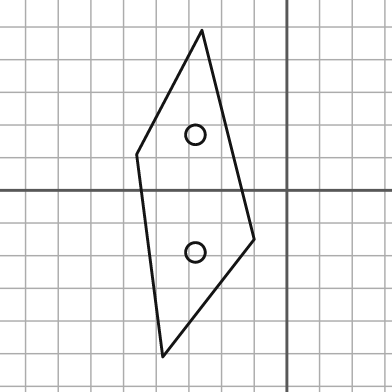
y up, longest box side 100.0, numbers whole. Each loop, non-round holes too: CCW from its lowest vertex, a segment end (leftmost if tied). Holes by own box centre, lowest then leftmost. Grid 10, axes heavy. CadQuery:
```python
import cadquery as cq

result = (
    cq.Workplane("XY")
    .moveTo(-38.0, -51.0)
    .lineTo(-10.0, -15.0)
    .lineTo(-26.0, 49.0)
    .lineTo(-46.0, 11.0)
    .close()
    .moveTo(-28.0, -19.0)
    .circle(3.0)
    .moveTo(-28.0, 17.0)
    .circle(3.0)
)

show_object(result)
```